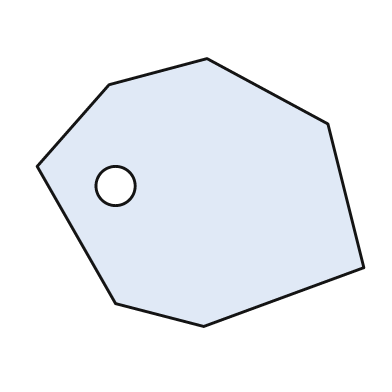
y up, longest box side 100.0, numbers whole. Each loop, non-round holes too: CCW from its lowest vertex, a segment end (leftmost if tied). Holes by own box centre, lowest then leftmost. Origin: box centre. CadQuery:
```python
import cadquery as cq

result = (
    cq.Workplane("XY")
    .moveTo(1.0, -41.0)
    .lineTo(50.0, -23.0)
    .lineTo(39.0, 21.0)
    .lineTo(2.0, 41.0)
    .lineTo(-28.0, 33.0)
    .lineTo(-50.0, 8.0)
    .lineTo(-26.0, -34.0)
    .close()
    .moveTo(-26.0, 2.0)
    .circle(6.0)
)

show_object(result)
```